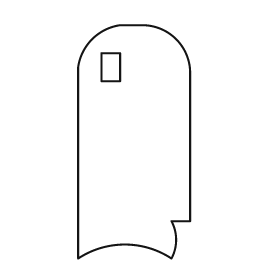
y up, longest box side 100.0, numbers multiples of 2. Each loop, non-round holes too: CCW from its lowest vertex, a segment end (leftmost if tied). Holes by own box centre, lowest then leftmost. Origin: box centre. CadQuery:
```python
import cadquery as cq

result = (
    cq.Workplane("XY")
    .moveTo(-24.0, -50.0)
    .threePointArc((-4.0, -44.0), (16.0, -50.0))
    .threePointArc((18.0, -42.0), (16.0, -34.0))
    .lineTo(24.0, -34.0)
    .lineTo(24.0, 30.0)
    .threePointArc((18.0, 44.0), (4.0, 50.0))
    .lineTo(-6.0, 50.0)
    .threePointArc((-18.0, 44.0), (-24.0, 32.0))
    .close()
    .moveTo(-14.0, 26.0)
    .lineTo(-6.0, 26.0)
    .lineTo(-6.0, 38.0)
    .lineTo(-14.0, 38.0)
    .close()
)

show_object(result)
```